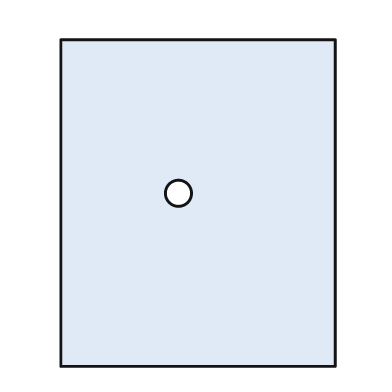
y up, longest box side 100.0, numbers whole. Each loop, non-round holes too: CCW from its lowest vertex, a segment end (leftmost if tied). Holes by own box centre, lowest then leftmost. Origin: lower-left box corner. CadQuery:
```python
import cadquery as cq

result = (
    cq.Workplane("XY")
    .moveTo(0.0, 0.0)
    .lineTo(84.0, 0.0)
    .lineTo(84.0, 100.0)
    .lineTo(0.0, 100.0)
    .close()
    .moveTo(36.0, 53.0)
    .circle(4.0)
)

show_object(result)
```